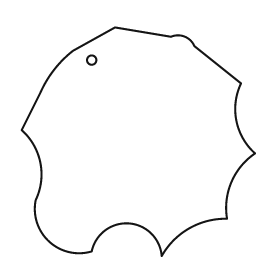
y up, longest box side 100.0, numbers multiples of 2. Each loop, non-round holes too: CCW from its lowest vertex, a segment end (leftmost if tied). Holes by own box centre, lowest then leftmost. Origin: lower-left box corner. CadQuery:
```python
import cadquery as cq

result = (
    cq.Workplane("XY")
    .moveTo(60.0, 0.0)
    .threePointArc((72.0, 12.0), (88.0, 16.0))
    .threePointArc((90.0, 32.0), (100.0, 44.0))
    .threePointArc((92.0, 58.0), (94.0, 74.0))
    .lineTo(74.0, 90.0)
    .threePointArc((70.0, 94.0), (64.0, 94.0))
    .lineTo(40.0, 98.0)
    .lineTo(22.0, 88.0)
    .threePointArc((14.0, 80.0), (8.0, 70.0))
    .lineTo(0.0, 54.0)
    .threePointArc((8.0, 40.0), (6.0, 24.0))
    .threePointArc((12.0, 6.0), (30.0, 2.0))
    .threePointArc((46.0, 14.0), (60.0, 0.0))
    .close()
    .moveTo(30.0, 84.0)
    .circle(2.0)
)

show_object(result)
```